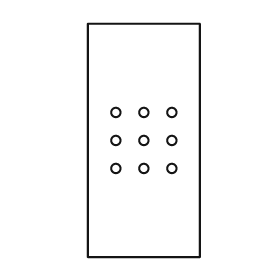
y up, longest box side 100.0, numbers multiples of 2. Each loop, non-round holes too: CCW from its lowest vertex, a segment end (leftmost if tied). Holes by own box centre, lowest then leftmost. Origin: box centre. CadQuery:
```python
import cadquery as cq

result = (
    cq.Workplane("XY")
    .moveTo(-24.0, -50.0)
    .lineTo(24.0, -50.0)
    .lineTo(24.0, 50.0)
    .lineTo(-24.0, 50.0)
    .close()
    .moveTo(-12.0, -12.0)
    .circle(2.0)
    .moveTo(0.0, -12.0)
    .circle(2.0)
    .moveTo(12.0, -12.0)
    .circle(2.0)
    .moveTo(-12.0, 0.0)
    .circle(2.0)
    .moveTo(0.0, 0.0)
    .circle(2.0)
    .moveTo(12.0, 0.0)
    .circle(2.0)
    .moveTo(-12.0, 12.0)
    .circle(2.0)
    .moveTo(0.0, 12.0)
    .circle(2.0)
    .moveTo(12.0, 12.0)
    .circle(2.0)
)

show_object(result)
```